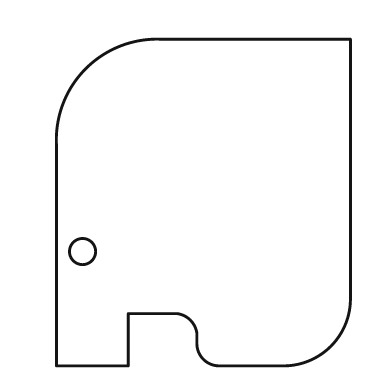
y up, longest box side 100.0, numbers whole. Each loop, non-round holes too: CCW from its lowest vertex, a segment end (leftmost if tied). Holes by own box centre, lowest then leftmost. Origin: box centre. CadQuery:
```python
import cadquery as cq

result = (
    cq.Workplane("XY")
    .moveTo(-45.0, -50.0)
    .lineTo(-23.0, -50.0)
    .lineTo(-23.0, -34.0)
    .lineTo(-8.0, -34.0)
    .threePointArc((-4.0, -36.0), (-2.0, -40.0))
    .lineTo(-2.0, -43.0)
    .threePointArc((0.0, -48.0), (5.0, -50.0))
    .lineTo(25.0, -50.0)
    .threePointArc((39.0, -44.0), (45.0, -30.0))
    .lineTo(45.0, 50.0)
    .lineTo(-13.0, 50.0)
    .threePointArc((-36.0, 41.0), (-45.0, 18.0))
    .close()
    .moveTo(-37.0, -15.0)
    .circle(4.0)
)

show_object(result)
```